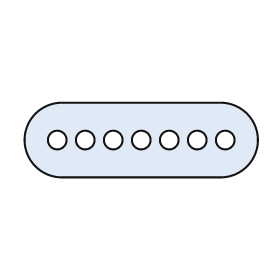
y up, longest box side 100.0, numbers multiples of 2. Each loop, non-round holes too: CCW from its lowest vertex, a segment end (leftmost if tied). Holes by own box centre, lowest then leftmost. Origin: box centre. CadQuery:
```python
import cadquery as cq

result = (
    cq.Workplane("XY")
    .moveTo(-34.0, -16.0)
    .lineTo(34.0, -16.0)
    .threePointArc((50.0, 0.0), (34.0, 16.0))
    .lineTo(-34.0, 16.0)
    .threePointArc((-50.0, 0.0), (-34.0, -16.0))
    .close()
    .moveTo(-36.0, 0.0)
    .circle(4.0)
    .moveTo(-24.0, 0.0)
    .circle(4.0)
    .moveTo(-12.0, 0.0)
    .circle(4.0)
    .moveTo(0.0, 0.0)
    .circle(4.0)
    .moveTo(12.0, 0.0)
    .circle(4.0)
    .moveTo(24.0, 0.0)
    .circle(4.0)
    .moveTo(36.0, 0.0)
    .circle(4.0)
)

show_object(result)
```